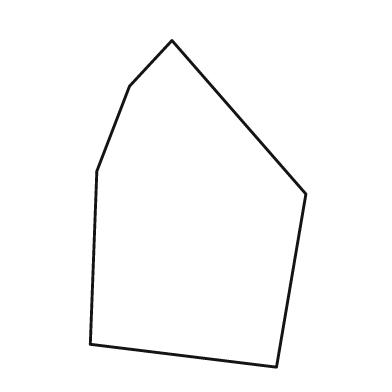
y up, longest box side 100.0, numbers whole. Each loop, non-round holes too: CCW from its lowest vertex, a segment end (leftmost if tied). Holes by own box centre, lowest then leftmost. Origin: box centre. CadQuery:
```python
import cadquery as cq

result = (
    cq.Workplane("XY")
    .moveTo(24.0, -50.0)
    .lineTo(33.0, 3.0)
    .lineTo(-8.0, 50.0)
    .lineTo(-21.0, 36.0)
    .lineTo(-31.0, 10.0)
    .lineTo(-33.0, -43.0)
    .close()
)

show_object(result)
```